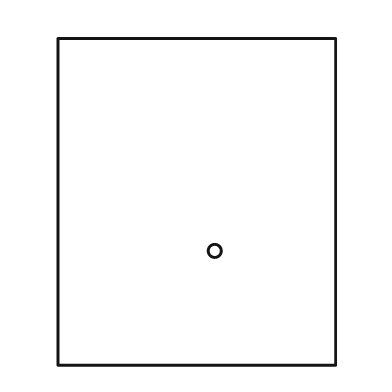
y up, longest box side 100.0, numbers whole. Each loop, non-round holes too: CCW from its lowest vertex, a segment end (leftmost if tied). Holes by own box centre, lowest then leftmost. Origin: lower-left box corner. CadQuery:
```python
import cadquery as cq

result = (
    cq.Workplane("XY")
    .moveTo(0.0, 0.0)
    .lineTo(85.0, 0.0)
    .lineTo(85.0, 100.0)
    .lineTo(0.0, 100.0)
    .close()
    .moveTo(48.0, 35.0)
    .circle(2.0)
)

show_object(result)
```